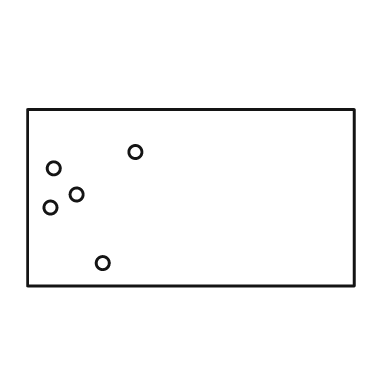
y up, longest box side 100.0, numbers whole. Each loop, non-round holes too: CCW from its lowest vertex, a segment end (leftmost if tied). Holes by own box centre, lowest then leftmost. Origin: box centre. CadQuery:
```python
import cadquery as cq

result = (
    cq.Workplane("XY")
    .moveTo(-50.0, -27.0)
    .lineTo(50.0, -27.0)
    .lineTo(50.0, 27.0)
    .lineTo(-50.0, 27.0)
    .close()
    .moveTo(-27.0, -20.0)
    .circle(2.0)
    .moveTo(-43.0, -3.0)
    .circle(2.0)
    .moveTo(-35.0, 1.0)
    .circle(2.0)
    .moveTo(-42.0, 9.0)
    .circle(2.0)
    .moveTo(-17.0, 14.0)
    .circle(2.0)
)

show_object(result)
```